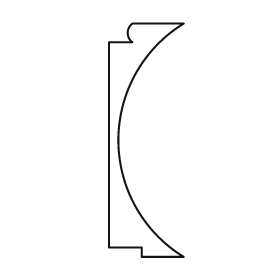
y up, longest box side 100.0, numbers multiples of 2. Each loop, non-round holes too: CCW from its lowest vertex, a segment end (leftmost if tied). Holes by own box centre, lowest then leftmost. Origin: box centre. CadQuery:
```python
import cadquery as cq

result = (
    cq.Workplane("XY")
    .moveTo(-2.0, -50.0)
    .lineTo(16.0, -50.0)
    .threePointArc((-12.0, 0.0), (16.0, 50.0))
    .lineTo(-6.0, 50.0)
    .threePointArc((-8.0, 46.0), (-6.0, 42.0))
    .lineTo(-16.0, 42.0)
    .lineTo(-16.0, -46.0)
    .lineTo(-2.0, -46.0)
    .close()
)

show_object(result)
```